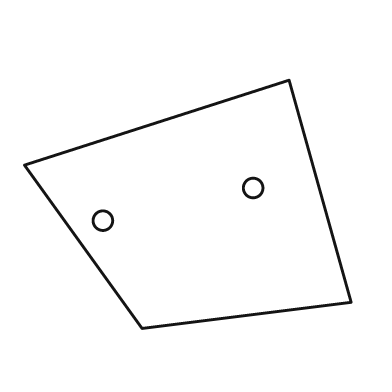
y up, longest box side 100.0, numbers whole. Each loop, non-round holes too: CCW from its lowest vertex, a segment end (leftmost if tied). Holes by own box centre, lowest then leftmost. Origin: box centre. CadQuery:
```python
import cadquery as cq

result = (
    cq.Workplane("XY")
    .moveTo(-14.0, -38.0)
    .lineTo(50.0, -30.0)
    .lineTo(31.0, 38.0)
    .lineTo(-50.0, 12.0)
    .close()
    .moveTo(-26.0, -5.0)
    .circle(3.0)
    .moveTo(20.0, 5.0)
    .circle(3.0)
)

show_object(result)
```